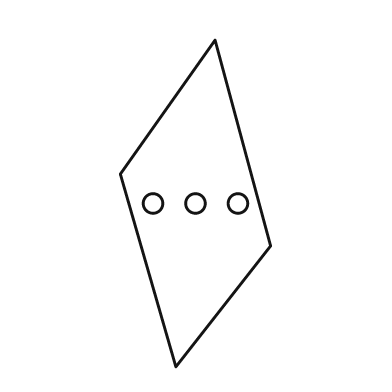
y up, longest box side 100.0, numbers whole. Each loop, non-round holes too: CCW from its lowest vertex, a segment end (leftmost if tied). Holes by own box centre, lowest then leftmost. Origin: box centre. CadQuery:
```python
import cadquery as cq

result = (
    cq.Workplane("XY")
    .moveTo(-6.0, -50.0)
    .lineTo(23.0, -13.0)
    .lineTo(6.0, 50.0)
    .lineTo(-23.0, 9.0)
    .close()
    .moveTo(-13.0, 0.0)
    .circle(3.0)
    .moveTo(0.0, 0.0)
    .circle(3.0)
    .moveTo(13.0, 0.0)
    .circle(3.0)
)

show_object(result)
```